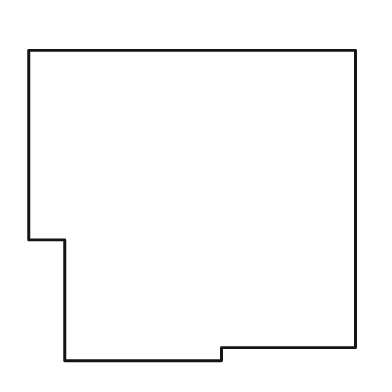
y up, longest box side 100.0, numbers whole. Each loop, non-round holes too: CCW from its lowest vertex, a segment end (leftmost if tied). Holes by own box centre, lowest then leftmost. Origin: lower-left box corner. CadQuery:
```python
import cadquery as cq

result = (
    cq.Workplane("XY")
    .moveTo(11.0, 0.0)
    .lineTo(59.0, 0.0)
    .lineTo(59.0, 4.0)
    .lineTo(100.0, 4.0)
    .lineTo(100.0, 95.0)
    .lineTo(0.0, 95.0)
    .lineTo(0.0, 37.0)
    .lineTo(11.0, 37.0)
    .close()
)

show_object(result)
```